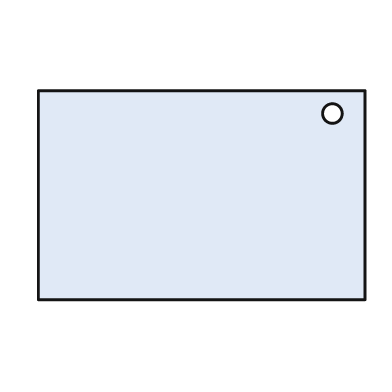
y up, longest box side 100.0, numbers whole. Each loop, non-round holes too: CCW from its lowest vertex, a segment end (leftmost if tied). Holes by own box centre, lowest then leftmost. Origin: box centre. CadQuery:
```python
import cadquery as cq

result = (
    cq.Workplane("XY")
    .moveTo(-50.0, -32.0)
    .lineTo(50.0, -32.0)
    .lineTo(50.0, 32.0)
    .lineTo(-50.0, 32.0)
    .close()
    .moveTo(40.0, 25.0)
    .circle(3.0)
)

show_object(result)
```